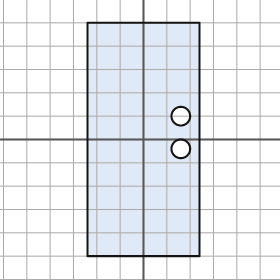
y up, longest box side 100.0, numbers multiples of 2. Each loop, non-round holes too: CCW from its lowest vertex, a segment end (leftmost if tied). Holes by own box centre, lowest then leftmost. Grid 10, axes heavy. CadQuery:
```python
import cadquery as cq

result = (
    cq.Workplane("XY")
    .moveTo(-24.0, -50.0)
    .lineTo(24.0, -50.0)
    .lineTo(24.0, 50.0)
    .lineTo(-24.0, 50.0)
    .close()
    .moveTo(16.0, -4.0)
    .circle(4.0)
    .moveTo(16.0, 10.0)
    .circle(4.0)
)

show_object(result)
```